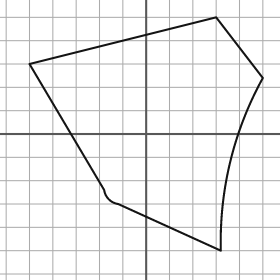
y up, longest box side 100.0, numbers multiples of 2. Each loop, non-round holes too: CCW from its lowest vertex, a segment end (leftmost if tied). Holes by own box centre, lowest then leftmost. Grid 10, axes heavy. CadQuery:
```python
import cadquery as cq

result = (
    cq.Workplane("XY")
    .moveTo(32.0, -50.0)
    .threePointArc((36.0, -12.0), (50.0, 24.0))
    .lineTo(30.0, 50.0)
    .lineTo(-50.0, 30.0)
    .lineTo(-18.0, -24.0)
    .threePointArc((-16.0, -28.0), (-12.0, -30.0))
    .close()
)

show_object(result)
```